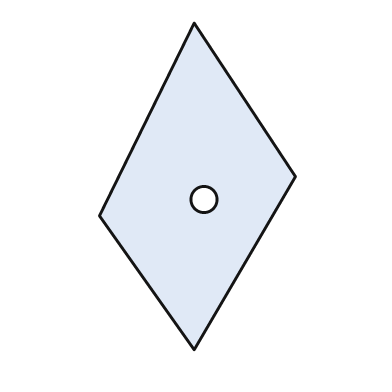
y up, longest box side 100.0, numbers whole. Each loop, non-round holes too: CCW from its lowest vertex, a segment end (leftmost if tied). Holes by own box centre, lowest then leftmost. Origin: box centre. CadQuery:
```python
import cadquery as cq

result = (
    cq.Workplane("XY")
    .moveTo(-1.0, -50.0)
    .lineTo(30.0, 3.0)
    .lineTo(-1.0, 50.0)
    .lineTo(-30.0, -9.0)
    .close()
    .moveTo(2.0, -4.0)
    .circle(4.0)
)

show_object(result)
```